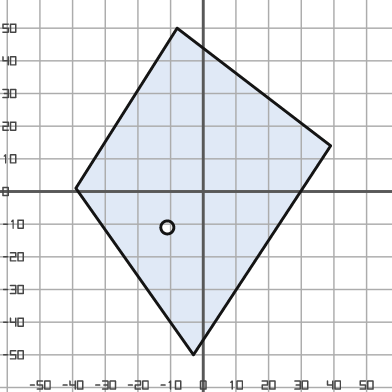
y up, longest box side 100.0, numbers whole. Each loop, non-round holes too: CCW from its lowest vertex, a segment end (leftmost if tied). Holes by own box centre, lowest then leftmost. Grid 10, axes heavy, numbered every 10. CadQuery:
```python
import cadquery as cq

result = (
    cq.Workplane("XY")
    .moveTo(-3.0, -50.0)
    .lineTo(39.0, 14.0)
    .lineTo(-8.0, 50.0)
    .lineTo(-39.0, 1.0)
    .close()
    .moveTo(-11.0, -11.0)
    .circle(2.0)
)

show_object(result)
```